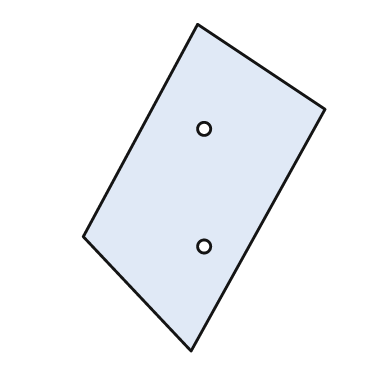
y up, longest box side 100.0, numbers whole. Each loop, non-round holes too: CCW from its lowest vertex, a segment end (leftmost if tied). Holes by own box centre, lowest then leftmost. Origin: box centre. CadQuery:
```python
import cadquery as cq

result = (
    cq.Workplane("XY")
    .moveTo(-4.0, -50.0)
    .lineTo(37.0, 24.0)
    .lineTo(-2.0, 50.0)
    .lineTo(-37.0, -15.0)
    .close()
    .moveTo(0.0, -18.0)
    .circle(2.0)
    .moveTo(0.0, 18.0)
    .circle(2.0)
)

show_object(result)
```